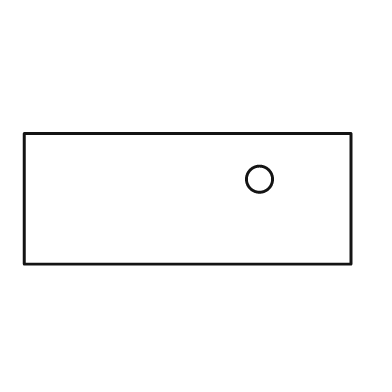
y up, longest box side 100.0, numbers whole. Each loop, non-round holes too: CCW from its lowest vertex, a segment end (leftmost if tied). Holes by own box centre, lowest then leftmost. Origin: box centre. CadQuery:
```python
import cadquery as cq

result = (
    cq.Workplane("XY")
    .moveTo(-50.0, -20.0)
    .lineTo(50.0, -20.0)
    .lineTo(50.0, 20.0)
    .lineTo(-50.0, 20.0)
    .close()
    .moveTo(22.0, 6.0)
    .circle(4.0)
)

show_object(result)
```